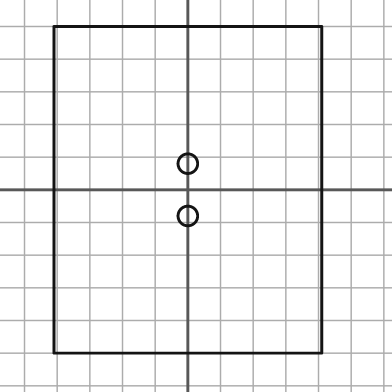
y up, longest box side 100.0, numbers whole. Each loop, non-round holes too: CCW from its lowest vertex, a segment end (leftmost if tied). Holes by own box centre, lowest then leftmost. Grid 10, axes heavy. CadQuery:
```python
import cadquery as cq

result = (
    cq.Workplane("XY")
    .moveTo(-41.0, -50.0)
    .lineTo(41.0, -50.0)
    .lineTo(41.0, 50.0)
    .lineTo(-41.0, 50.0)
    .close()
    .moveTo(0.0, -8.0)
    .circle(3.0)
    .moveTo(0.0, 8.0)
    .circle(3.0)
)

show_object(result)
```